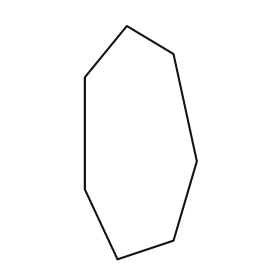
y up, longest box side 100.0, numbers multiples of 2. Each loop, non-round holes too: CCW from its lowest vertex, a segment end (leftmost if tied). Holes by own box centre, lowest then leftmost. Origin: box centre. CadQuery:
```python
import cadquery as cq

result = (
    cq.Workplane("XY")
    .moveTo(-10.0, -50.0)
    .lineTo(14.0, -42.0)
    .lineTo(24.0, -8.0)
    .lineTo(14.0, 38.0)
    .lineTo(-6.0, 50.0)
    .lineTo(-24.0, 28.0)
    .lineTo(-24.0, -20.0)
    .close()
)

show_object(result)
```